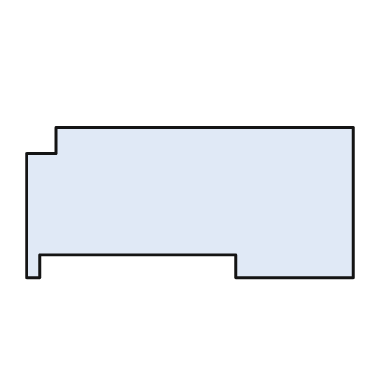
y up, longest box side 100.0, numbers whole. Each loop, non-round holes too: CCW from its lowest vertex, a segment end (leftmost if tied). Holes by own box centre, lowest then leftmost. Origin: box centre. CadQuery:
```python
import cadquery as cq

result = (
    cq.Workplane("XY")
    .moveTo(-50.0, -23.0)
    .lineTo(-46.0, -23.0)
    .lineTo(-46.0, -16.0)
    .lineTo(14.0, -16.0)
    .lineTo(14.0, -23.0)
    .lineTo(50.0, -23.0)
    .lineTo(50.0, 23.0)
    .lineTo(-41.0, 23.0)
    .lineTo(-41.0, 15.0)
    .lineTo(-50.0, 15.0)
    .close()
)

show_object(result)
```